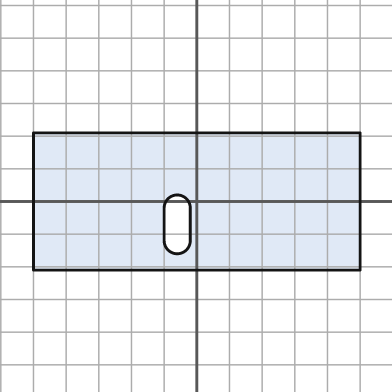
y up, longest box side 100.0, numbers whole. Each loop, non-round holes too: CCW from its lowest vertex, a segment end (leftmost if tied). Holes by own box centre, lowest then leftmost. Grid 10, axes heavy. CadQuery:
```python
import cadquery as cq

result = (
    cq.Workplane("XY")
    .moveTo(-50.0, -21.0)
    .lineTo(50.0, -21.0)
    .lineTo(50.0, 21.0)
    .lineTo(-50.0, 21.0)
    .close()
    .moveTo(-10.0, -12.0)
    .threePointArc((-6.0, -16.0), (-2.0, -12.0))
    .lineTo(-2.0, -2.0)
    .threePointArc((-6.0, 2.0), (-10.0, -2.0))
    .close()
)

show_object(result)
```